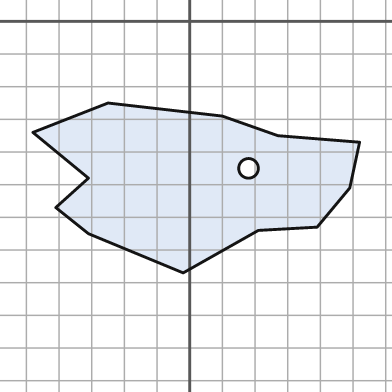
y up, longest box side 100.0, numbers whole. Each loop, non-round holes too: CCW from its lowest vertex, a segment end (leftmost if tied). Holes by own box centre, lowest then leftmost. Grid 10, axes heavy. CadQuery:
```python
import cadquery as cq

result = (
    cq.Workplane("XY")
    .moveTo(-2.0, -77.0)
    .lineTo(21.0, -64.0)
    .lineTo(39.0, -63.0)
    .lineTo(49.0, -51.0)
    .lineTo(52.0, -37.0)
    .lineTo(27.0, -35.0)
    .lineTo(10.0, -29.0)
    .lineTo(-25.0, -25.0)
    .lineTo(-48.0, -34.0)
    .lineTo(-31.0, -48.0)
    .lineTo(-41.0, -57.0)
    .lineTo(-31.0, -65.0)
    .close()
    .moveTo(18.0, -45.0)
    .circle(3.0)
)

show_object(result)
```